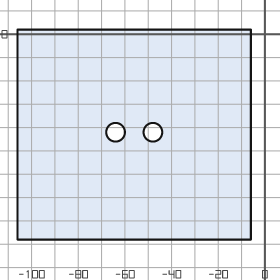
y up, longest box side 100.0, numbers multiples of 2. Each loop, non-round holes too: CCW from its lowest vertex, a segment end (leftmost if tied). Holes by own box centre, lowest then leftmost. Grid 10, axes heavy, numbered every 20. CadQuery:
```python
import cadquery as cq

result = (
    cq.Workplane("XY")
    .moveTo(-106.0, -88.0)
    .lineTo(-6.0, -88.0)
    .lineTo(-6.0, 2.0)
    .lineTo(-106.0, 2.0)
    .close()
    .moveTo(-64.0, -42.0)
    .circle(4.0)
    .moveTo(-48.0, -42.0)
    .circle(4.0)
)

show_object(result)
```